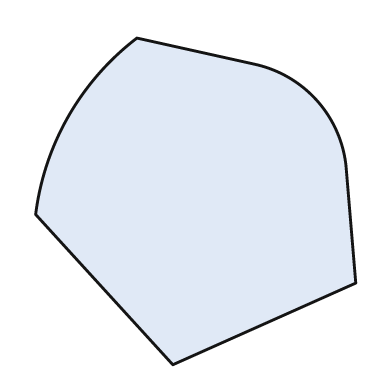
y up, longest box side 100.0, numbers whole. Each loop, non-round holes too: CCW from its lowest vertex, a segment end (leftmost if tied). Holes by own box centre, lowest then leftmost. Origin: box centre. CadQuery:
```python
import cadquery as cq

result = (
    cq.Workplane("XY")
    .moveTo(-7.0, -50.0)
    .lineTo(49.0, -25.0)
    .lineTo(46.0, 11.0)
    .threePointArc((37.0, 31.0), (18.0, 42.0))
    .lineTo(-18.0, 50.0)
    .threePointArc((-39.0, 26.0), (-49.0, -4.0))
    .close()
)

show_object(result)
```